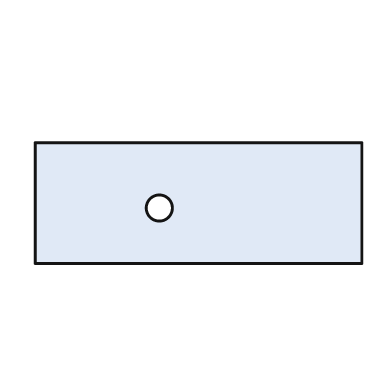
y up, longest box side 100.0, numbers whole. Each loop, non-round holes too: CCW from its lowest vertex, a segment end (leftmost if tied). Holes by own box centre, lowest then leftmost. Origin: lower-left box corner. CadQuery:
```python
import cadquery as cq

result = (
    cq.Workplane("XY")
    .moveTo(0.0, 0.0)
    .lineTo(100.0, 0.0)
    .lineTo(100.0, 37.0)
    .lineTo(0.0, 37.0)
    .close()
    .moveTo(38.0, 17.0)
    .circle(4.0)
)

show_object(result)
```